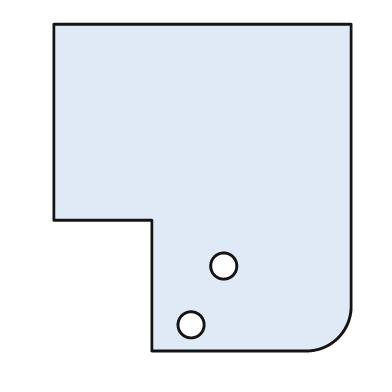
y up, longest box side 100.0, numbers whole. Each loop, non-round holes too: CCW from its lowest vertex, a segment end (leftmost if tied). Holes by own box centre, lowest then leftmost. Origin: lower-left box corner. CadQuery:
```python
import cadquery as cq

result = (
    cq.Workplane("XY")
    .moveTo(30.0, 0.0)
    .lineTo(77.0, 0.0)
    .threePointArc((87.0, 4.0), (91.0, 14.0))
    .lineTo(91.0, 100.0)
    .lineTo(0.0, 100.0)
    .lineTo(0.0, 40.0)
    .lineTo(30.0, 40.0)
    .close()
    .moveTo(42.0, 8.0)
    .circle(4.0)
    .moveTo(52.0, 26.0)
    .circle(4.0)
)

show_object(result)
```